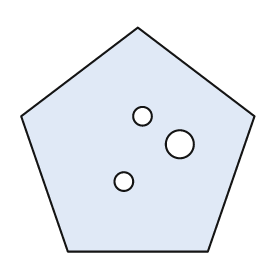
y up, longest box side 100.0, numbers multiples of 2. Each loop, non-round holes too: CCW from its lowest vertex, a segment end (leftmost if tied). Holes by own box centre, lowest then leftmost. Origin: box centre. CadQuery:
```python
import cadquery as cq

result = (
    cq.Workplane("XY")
    .moveTo(-30.0, -48.0)
    .lineTo(30.0, -48.0)
    .lineTo(50.0, 10.0)
    .lineTo(0.0, 48.0)
    .lineTo(-50.0, 10.0)
    .close()
    .moveTo(-6.0, -18.0)
    .circle(4.0)
    .moveTo(18.0, -2.0)
    .circle(6.0)
    .moveTo(2.0, 10.0)
    .circle(4.0)
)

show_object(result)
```